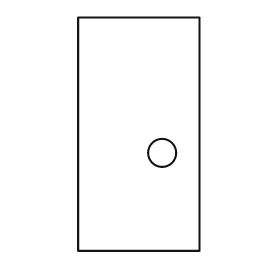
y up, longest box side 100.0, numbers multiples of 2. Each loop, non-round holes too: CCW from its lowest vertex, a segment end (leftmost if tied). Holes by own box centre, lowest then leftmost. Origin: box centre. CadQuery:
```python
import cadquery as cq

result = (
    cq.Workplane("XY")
    .moveTo(-26.0, -50.0)
    .lineTo(26.0, -50.0)
    .lineTo(26.0, 50.0)
    .lineTo(-26.0, 50.0)
    .close()
    .moveTo(10.0, -8.0)
    .circle(6.0)
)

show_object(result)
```